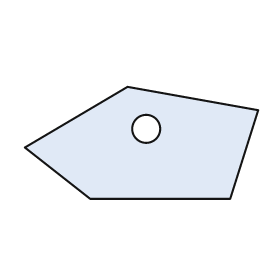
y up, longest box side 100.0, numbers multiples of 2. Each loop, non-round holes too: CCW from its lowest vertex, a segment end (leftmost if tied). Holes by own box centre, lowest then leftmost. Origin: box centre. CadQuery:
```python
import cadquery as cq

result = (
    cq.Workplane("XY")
    .moveTo(-22.0, -24.0)
    .lineTo(38.0, -24.0)
    .lineTo(50.0, 14.0)
    .lineTo(-6.0, 24.0)
    .lineTo(-50.0, -2.0)
    .close()
    .moveTo(2.0, 6.0)
    .circle(6.0)
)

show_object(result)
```